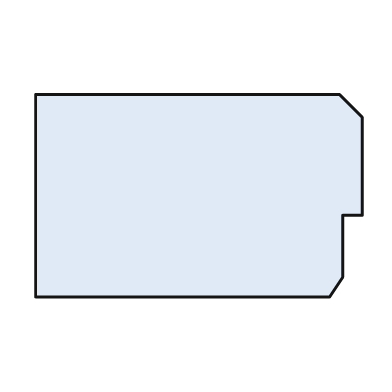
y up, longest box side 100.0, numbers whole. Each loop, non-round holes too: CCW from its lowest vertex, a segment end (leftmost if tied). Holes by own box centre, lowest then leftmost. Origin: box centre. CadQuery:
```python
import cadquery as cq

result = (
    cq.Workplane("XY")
    .moveTo(-50.0, -31.0)
    .lineTo(40.0, -31.0)
    .lineTo(44.0, -25.0)
    .lineTo(44.0, -6.0)
    .lineTo(50.0, -6.0)
    .lineTo(50.0, 24.0)
    .lineTo(43.0, 31.0)
    .lineTo(-50.0, 31.0)
    .close()
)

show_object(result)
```